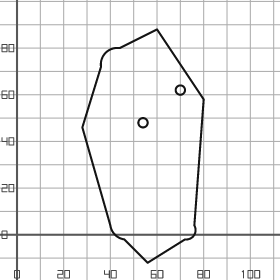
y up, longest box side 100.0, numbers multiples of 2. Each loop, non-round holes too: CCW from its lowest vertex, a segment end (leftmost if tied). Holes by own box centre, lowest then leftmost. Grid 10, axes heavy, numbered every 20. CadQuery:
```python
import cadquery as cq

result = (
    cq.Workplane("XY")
    .moveTo(56.0, -12.0)
    .lineTo(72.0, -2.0)
    .threePointArc((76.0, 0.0), (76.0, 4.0))
    .lineTo(80.0, 58.0)
    .lineTo(60.0, 88.0)
    .lineTo(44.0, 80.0)
    .threePointArc((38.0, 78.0), (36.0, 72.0))
    .lineTo(28.0, 46.0)
    .lineTo(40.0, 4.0)
    .threePointArc((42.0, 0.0), (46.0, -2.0))
    .close()
    .moveTo(54.0, 48.0)
    .circle(2.0)
    .moveTo(70.0, 62.0)
    .circle(2.0)
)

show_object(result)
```